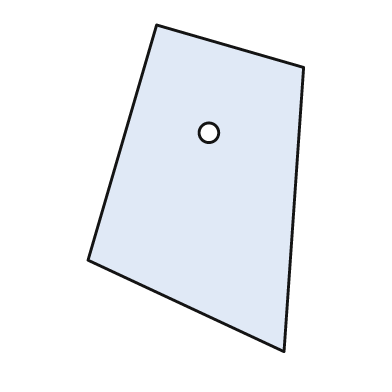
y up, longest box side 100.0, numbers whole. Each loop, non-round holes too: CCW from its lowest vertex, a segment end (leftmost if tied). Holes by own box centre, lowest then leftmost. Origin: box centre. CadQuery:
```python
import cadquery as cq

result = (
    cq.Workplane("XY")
    .moveTo(27.0, -50.0)
    .lineTo(33.0, 37.0)
    .lineTo(-12.0, 50.0)
    .lineTo(-33.0, -22.0)
    .close()
    .moveTo(4.0, 17.0)
    .circle(3.0)
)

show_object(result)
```